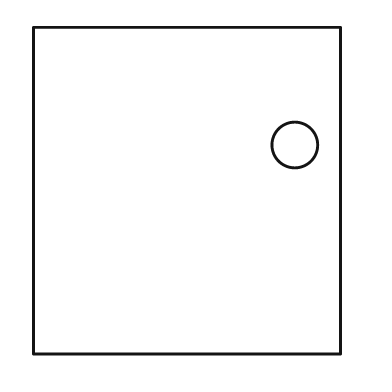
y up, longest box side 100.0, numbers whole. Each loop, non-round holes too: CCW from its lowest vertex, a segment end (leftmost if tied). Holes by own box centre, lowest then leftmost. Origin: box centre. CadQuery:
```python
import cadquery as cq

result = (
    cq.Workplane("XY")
    .moveTo(-47.0, -50.0)
    .lineTo(47.0, -50.0)
    .lineTo(47.0, 50.0)
    .lineTo(-47.0, 50.0)
    .close()
    .moveTo(33.0, 14.0)
    .circle(7.0)
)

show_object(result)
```